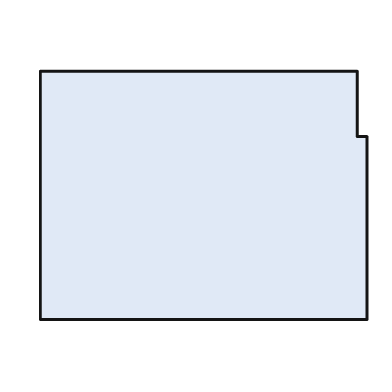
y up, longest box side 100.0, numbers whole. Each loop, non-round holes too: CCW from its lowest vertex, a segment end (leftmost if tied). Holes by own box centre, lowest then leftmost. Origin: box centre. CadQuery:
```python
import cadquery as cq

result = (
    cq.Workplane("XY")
    .moveTo(-50.0, -38.0)
    .lineTo(50.0, -38.0)
    .lineTo(50.0, 18.0)
    .lineTo(47.0, 18.0)
    .lineTo(47.0, 38.0)
    .lineTo(-50.0, 38.0)
    .close()
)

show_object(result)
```